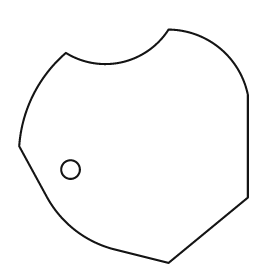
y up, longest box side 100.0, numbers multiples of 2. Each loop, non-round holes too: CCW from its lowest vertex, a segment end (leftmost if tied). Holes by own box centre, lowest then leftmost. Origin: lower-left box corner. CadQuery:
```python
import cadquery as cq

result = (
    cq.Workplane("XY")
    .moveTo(64.0, 0.0)
    .lineTo(98.0, 28.0)
    .lineTo(98.0, 72.0)
    .threePointArc((86.0, 92.0), (64.0, 100.0))
    .threePointArc((44.0, 86.0), (20.0, 90.0))
    .threePointArc((6.0, 72.0), (0.0, 50.0))
    .lineTo(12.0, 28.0)
    .threePointArc((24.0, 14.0), (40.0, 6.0))
    .close()
    .moveTo(22.0, 40.0)
    .circle(4.0)
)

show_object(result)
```